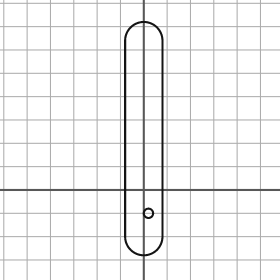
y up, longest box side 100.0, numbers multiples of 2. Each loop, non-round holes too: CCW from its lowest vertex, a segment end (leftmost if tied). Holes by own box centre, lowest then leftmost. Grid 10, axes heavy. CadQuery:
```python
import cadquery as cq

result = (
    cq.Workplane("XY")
    .moveTo(-8.0, -20.0)
    .threePointArc((0.0, -28.0), (8.0, -20.0))
    .lineTo(8.0, 64.0)
    .threePointArc((0.0, 72.0), (-8.0, 64.0))
    .close()
    .moveTo(2.0, -10.0)
    .circle(2.0)
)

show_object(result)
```